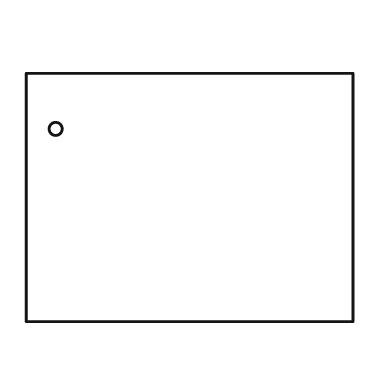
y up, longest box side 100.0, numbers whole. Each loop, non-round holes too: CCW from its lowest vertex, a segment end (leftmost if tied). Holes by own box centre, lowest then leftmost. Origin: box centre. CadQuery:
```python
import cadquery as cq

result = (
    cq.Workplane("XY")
    .moveTo(-50.0, -38.0)
    .lineTo(50.0, -38.0)
    .lineTo(50.0, 38.0)
    .lineTo(-50.0, 38.0)
    .close()
    .moveTo(-41.0, 21.0)
    .circle(2.0)
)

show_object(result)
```